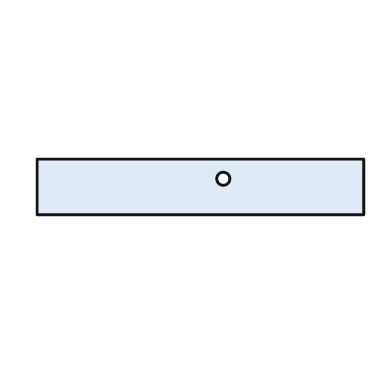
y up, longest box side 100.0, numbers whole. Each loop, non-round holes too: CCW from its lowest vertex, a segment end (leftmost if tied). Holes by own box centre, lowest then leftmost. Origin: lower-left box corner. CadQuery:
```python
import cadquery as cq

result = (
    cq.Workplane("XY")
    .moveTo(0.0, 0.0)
    .lineTo(100.0, 0.0)
    .lineTo(100.0, 17.0)
    .lineTo(0.0, 17.0)
    .close()
    .moveTo(57.0, 11.0)
    .circle(2.0)
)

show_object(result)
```